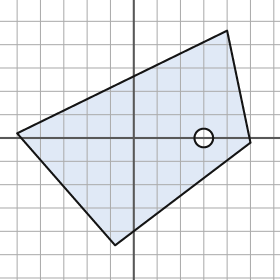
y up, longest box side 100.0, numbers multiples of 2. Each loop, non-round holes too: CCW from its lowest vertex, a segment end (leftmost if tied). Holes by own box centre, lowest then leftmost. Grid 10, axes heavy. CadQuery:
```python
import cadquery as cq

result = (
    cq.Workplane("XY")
    .moveTo(-8.0, -46.0)
    .lineTo(50.0, -2.0)
    .lineTo(40.0, 46.0)
    .lineTo(-50.0, 2.0)
    .close()
    .moveTo(30.0, 0.0)
    .circle(4.0)
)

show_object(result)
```